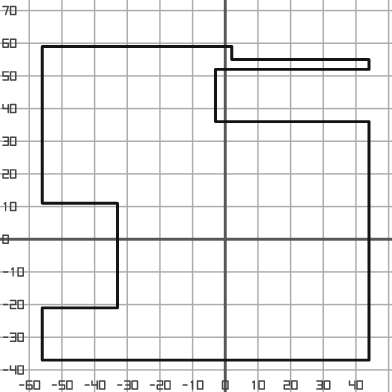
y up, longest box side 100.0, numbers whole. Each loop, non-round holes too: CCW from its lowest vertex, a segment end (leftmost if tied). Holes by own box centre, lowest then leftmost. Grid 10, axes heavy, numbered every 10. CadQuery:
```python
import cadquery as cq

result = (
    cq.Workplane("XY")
    .moveTo(-56.0, -37.0)
    .lineTo(44.0, -37.0)
    .lineTo(44.0, 36.0)
    .lineTo(-3.0, 36.0)
    .lineTo(-3.0, 52.0)
    .lineTo(44.0, 52.0)
    .lineTo(44.0, 55.0)
    .lineTo(2.0, 55.0)
    .lineTo(2.0, 59.0)
    .lineTo(-56.0, 59.0)
    .lineTo(-56.0, 11.0)
    .lineTo(-33.0, 11.0)
    .lineTo(-33.0, -21.0)
    .lineTo(-56.0, -21.0)
    .close()
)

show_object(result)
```